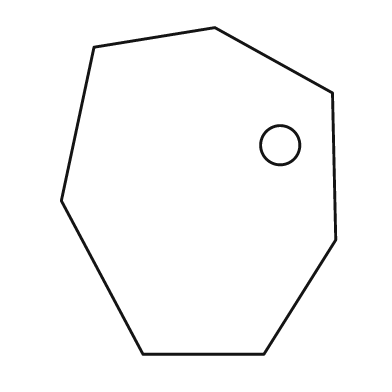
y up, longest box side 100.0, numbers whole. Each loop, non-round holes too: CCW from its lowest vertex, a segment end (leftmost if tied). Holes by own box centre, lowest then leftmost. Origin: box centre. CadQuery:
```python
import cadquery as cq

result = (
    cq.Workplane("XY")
    .moveTo(-17.0, -50.0)
    .lineTo(20.0, -50.0)
    .lineTo(42.0, -15.0)
    .lineTo(41.0, 30.0)
    .lineTo(5.0, 50.0)
    .lineTo(-32.0, 44.0)
    .lineTo(-42.0, -3.0)
    .close()
    .moveTo(25.0, 14.0)
    .circle(6.0)
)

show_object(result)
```